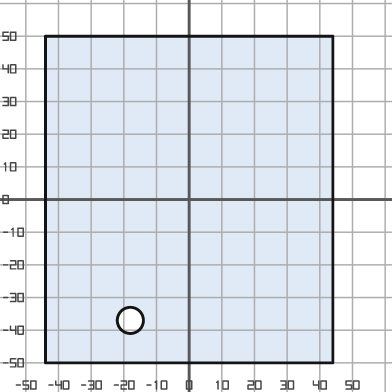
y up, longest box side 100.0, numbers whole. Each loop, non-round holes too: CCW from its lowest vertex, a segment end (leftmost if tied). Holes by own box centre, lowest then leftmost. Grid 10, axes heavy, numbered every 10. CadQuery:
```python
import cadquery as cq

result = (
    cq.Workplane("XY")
    .moveTo(-44.0, -50.0)
    .lineTo(44.0, -50.0)
    .lineTo(44.0, 50.0)
    .lineTo(-44.0, 50.0)
    .close()
    .moveTo(-18.0, -37.0)
    .circle(4.0)
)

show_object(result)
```